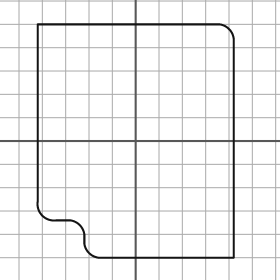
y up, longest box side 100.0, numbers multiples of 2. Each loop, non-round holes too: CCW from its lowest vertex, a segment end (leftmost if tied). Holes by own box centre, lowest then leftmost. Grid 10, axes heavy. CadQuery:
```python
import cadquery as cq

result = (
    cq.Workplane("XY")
    .moveTo(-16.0, -50.0)
    .lineTo(42.0, -50.0)
    .lineTo(42.0, 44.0)
    .threePointArc((40.0, 48.0), (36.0, 50.0))
    .lineTo(-42.0, 50.0)
    .lineTo(-42.0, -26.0)
    .threePointArc((-40.0, -32.0), (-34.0, -34.0))
    .lineTo(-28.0, -34.0)
    .threePointArc((-24.0, -36.0), (-22.0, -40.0))
    .lineTo(-22.0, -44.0)
    .threePointArc((-20.0, -48.0), (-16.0, -50.0))
    .close()
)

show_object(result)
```